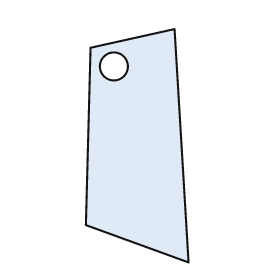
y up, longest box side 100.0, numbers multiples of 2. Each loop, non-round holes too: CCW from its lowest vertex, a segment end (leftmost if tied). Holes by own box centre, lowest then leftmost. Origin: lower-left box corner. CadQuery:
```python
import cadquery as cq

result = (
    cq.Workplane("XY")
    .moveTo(44.0, 0.0)
    .lineTo(38.0, 100.0)
    .lineTo(2.0, 92.0)
    .lineTo(0.0, 16.0)
    .close()
    .moveTo(12.0, 84.0)
    .circle(6.0)
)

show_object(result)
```